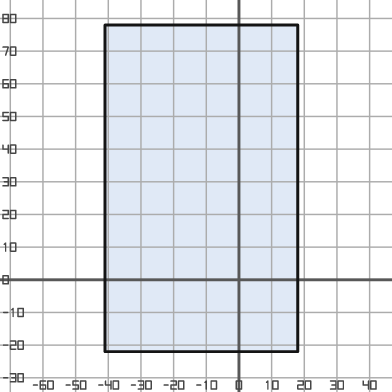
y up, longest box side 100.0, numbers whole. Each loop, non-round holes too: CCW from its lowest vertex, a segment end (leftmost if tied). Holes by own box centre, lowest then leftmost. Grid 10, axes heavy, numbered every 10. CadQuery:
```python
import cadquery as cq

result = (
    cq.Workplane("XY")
    .moveTo(-41.0, -22.0)
    .lineTo(18.0, -22.0)
    .lineTo(18.0, 78.0)
    .lineTo(-41.0, 78.0)
    .close()
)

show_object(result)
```